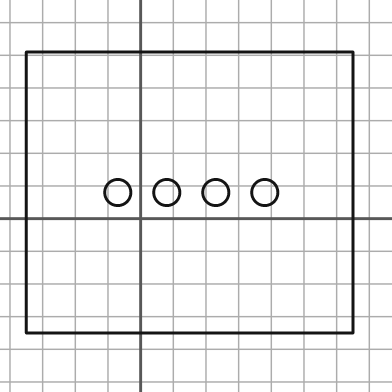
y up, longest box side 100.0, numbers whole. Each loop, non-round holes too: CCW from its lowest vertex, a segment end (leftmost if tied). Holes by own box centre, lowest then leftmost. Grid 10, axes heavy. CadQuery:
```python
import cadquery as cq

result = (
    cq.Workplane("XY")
    .moveTo(-35.0, -35.0)
    .lineTo(65.0, -35.0)
    .lineTo(65.0, 51.0)
    .lineTo(-35.0, 51.0)
    .close()
    .moveTo(-7.0, 8.0)
    .circle(4.0)
    .moveTo(8.0, 8.0)
    .circle(4.0)
    .moveTo(23.0, 8.0)
    .circle(4.0)
    .moveTo(38.0, 8.0)
    .circle(4.0)
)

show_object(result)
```